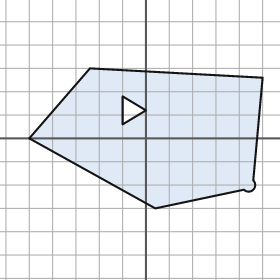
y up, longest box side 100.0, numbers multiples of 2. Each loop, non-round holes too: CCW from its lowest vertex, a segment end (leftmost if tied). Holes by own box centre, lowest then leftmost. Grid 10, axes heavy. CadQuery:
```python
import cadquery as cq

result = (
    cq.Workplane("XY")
    .moveTo(4.0, -30.0)
    .lineTo(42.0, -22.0)
    .threePointArc((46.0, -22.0), (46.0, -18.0))
    .lineTo(50.0, 26.0)
    .lineTo(-24.0, 30.0)
    .lineTo(-50.0, 0.0)
    .close()
    .moveTo(-10.0, 6.0)
    .lineTo(0.0, 12.0)
    .lineTo(-10.0, 18.0)
    .close()
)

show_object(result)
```